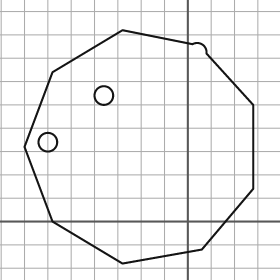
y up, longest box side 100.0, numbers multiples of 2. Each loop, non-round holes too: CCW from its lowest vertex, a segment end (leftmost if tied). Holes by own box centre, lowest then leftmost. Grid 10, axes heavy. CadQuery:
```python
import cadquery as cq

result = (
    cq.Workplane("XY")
    .moveTo(-28.0, -18.0)
    .lineTo(6.0, -12.0)
    .lineTo(28.0, 14.0)
    .lineTo(28.0, 50.0)
    .lineTo(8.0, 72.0)
    .threePointArc((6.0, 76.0), (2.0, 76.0))
    .lineTo(-28.0, 82.0)
    .lineTo(-58.0, 64.0)
    .lineTo(-70.0, 32.0)
    .lineTo(-58.0, 0.0)
    .close()
    .moveTo(-60.0, 34.0)
    .circle(4.0)
    .moveTo(-36.0, 54.0)
    .circle(4.0)
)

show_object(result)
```